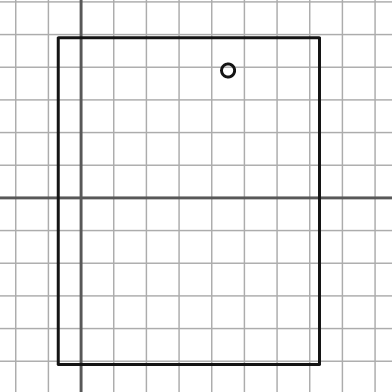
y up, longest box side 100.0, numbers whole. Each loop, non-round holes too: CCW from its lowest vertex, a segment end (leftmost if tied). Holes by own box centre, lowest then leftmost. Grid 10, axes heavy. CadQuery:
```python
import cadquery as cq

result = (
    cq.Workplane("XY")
    .moveTo(-7.0, -51.0)
    .lineTo(73.0, -51.0)
    .lineTo(73.0, 49.0)
    .lineTo(-7.0, 49.0)
    .close()
    .moveTo(45.0, 39.0)
    .circle(2.0)
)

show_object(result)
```